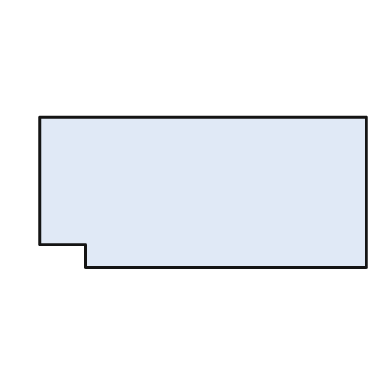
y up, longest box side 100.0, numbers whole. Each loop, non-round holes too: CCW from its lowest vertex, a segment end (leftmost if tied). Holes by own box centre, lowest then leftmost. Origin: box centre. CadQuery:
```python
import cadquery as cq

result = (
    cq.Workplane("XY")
    .moveTo(-36.0, -23.0)
    .lineTo(50.0, -23.0)
    .lineTo(50.0, 23.0)
    .lineTo(-50.0, 23.0)
    .lineTo(-50.0, -16.0)
    .lineTo(-36.0, -16.0)
    .close()
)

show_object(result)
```